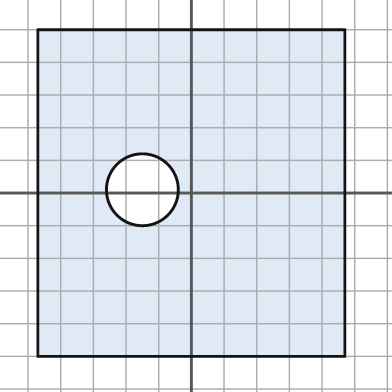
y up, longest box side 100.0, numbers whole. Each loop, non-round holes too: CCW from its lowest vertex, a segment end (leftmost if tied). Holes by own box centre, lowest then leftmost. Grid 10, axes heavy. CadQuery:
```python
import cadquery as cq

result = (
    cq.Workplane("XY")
    .moveTo(-47.0, -50.0)
    .lineTo(47.0, -50.0)
    .lineTo(47.0, 50.0)
    .lineTo(-47.0, 50.0)
    .close()
    .moveTo(-15.0, 1.0)
    .circle(11.0)
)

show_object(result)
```